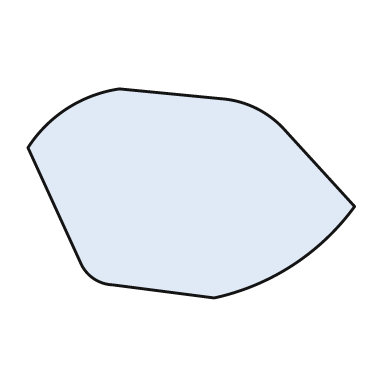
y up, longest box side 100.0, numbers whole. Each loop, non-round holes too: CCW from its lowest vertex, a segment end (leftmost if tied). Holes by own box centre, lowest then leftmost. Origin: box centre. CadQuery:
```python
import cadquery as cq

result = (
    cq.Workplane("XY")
    .moveTo(7.0, -32.0)
    .threePointArc((31.0, -22.0), (50.0, -4.0))
    .lineTo(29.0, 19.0)
    .threePointArc((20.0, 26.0), (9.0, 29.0))
    .lineTo(-22.0, 32.0)
    .threePointArc((-38.0, 26.0), (-50.0, 14.0))
    .lineTo(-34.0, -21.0)
    .threePointArc((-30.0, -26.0), (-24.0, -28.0))
    .close()
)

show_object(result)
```